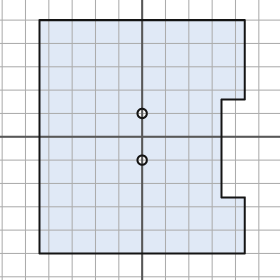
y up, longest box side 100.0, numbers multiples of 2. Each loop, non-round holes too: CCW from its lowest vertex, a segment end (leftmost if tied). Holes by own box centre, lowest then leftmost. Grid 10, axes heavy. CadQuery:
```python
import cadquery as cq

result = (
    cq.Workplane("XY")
    .moveTo(-44.0, -50.0)
    .lineTo(44.0, -50.0)
    .lineTo(44.0, -26.0)
    .lineTo(34.0, -26.0)
    .lineTo(34.0, 16.0)
    .lineTo(44.0, 16.0)
    .lineTo(44.0, 50.0)
    .lineTo(-44.0, 50.0)
    .close()
    .moveTo(0.0, -10.0)
    .circle(2.0)
    .moveTo(0.0, 10.0)
    .circle(2.0)
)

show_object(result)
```